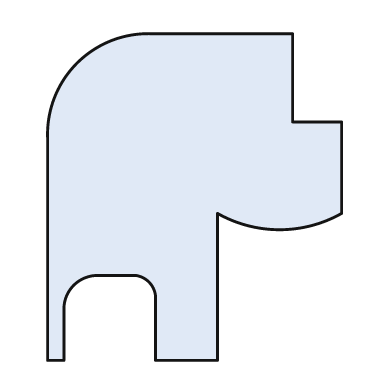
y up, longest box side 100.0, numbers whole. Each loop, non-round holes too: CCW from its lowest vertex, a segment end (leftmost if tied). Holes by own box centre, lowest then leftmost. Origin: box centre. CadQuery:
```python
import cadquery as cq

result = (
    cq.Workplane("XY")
    .moveTo(-45.0, -50.0)
    .lineTo(-40.0, -50.0)
    .lineTo(-40.0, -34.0)
    .threePointArc((-37.0, -27.0), (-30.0, -24.0))
    .lineTo(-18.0, -24.0)
    .threePointArc((-14.0, -26.0), (-12.0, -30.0))
    .lineTo(-12.0, -50.0)
    .lineTo(7.0, -50.0)
    .lineTo(7.0, -5.0)
    .threePointArc((26.0, -10.0), (45.0, -5.0))
    .lineTo(45.0, 23.0)
    .lineTo(30.0, 23.0)
    .lineTo(30.0, 50.0)
    .lineTo(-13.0, 50.0)
    .threePointArc((-36.0, 41.0), (-45.0, 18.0))
    .close()
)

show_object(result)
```